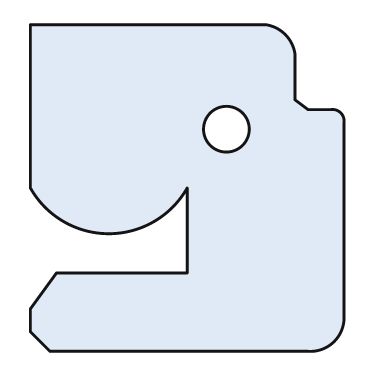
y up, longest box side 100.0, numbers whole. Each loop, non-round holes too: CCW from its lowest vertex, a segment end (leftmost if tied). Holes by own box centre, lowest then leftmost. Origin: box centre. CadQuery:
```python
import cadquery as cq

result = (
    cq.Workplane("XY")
    .moveTo(-42.0, -50.0)
    .lineTo(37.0, -50.0)
    .threePointArc((45.0, -47.0), (48.0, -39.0))
    .lineTo(48.0, 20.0)
    .threePointArc((47.0, 23.0), (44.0, 24.0))
    .lineTo(37.0, 24.0)
    .lineTo(33.0, 27.0)
    .lineTo(33.0, 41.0)
    .threePointArc((30.0, 47.0), (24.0, 50.0))
    .lineTo(-48.0, 50.0)
    .lineTo(-48.0, 0.0)
    .threePointArc((-24.0, -14.0), (0.0, 0.0))
    .lineTo(0.0, -26.0)
    .lineTo(-40.0, -26.0)
    .lineTo(-48.0, -37.0)
    .lineTo(-48.0, -44.0)
    .close()
    .moveTo(12.0, 18.0)
    .circle(7.0)
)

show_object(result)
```